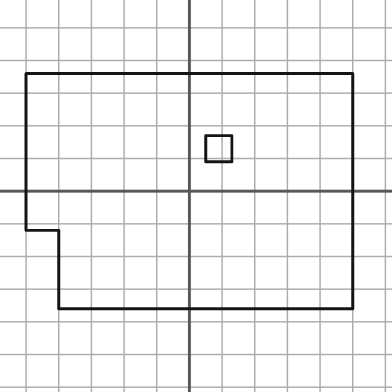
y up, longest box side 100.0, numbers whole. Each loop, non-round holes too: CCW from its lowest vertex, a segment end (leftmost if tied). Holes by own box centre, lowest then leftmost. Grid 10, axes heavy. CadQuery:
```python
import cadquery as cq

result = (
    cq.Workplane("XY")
    .moveTo(-40.0, -36.0)
    .lineTo(50.0, -36.0)
    .lineTo(50.0, 36.0)
    .lineTo(-50.0, 36.0)
    .lineTo(-50.0, -12.0)
    .lineTo(-40.0, -12.0)
    .close()
    .moveTo(5.0, 9.0)
    .lineTo(13.0, 9.0)
    .lineTo(13.0, 17.0)
    .lineTo(5.0, 17.0)
    .close()
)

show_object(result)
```